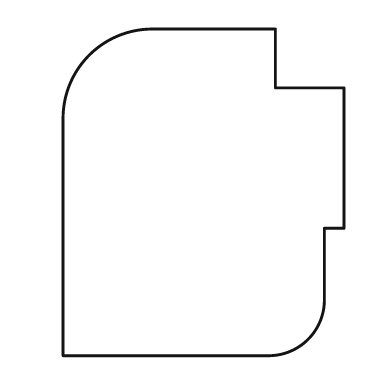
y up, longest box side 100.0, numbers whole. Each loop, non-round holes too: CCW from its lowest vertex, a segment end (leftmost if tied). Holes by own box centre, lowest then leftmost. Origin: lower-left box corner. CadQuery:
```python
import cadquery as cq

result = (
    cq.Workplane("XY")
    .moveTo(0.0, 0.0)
    .lineTo(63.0, 0.0)
    .threePointArc((75.0, 5.0), (80.0, 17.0))
    .lineTo(80.0, 39.0)
    .lineTo(86.0, 39.0)
    .lineTo(86.0, 82.0)
    .lineTo(65.0, 82.0)
    .lineTo(65.0, 100.0)
    .lineTo(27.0, 100.0)
    .threePointArc((8.0, 92.0), (0.0, 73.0))
    .close()
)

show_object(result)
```